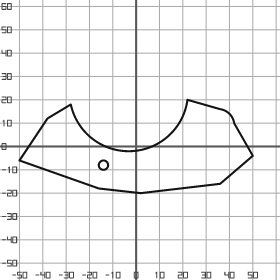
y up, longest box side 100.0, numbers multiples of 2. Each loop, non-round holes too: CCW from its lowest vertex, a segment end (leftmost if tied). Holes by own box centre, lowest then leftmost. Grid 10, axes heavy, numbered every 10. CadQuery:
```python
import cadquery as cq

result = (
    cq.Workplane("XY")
    .moveTo(2.0, -20.0)
    .lineTo(36.0, -16.0)
    .lineTo(50.0, -4.0)
    .lineTo(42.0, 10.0)
    .threePointArc((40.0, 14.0), (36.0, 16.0))
    .lineTo(22.0, 20.0)
    .threePointArc((-2.0, -2.0), (-28.0, 18.0))
    .lineTo(-38.0, 12.0)
    .lineTo(-50.0, -6.0)
    .lineTo(-16.0, -18.0)
    .close()
    .moveTo(-14.0, -8.0)
    .circle(2.0)
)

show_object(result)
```